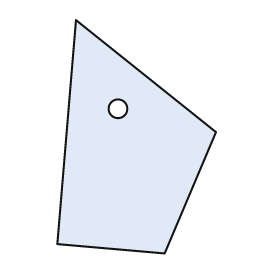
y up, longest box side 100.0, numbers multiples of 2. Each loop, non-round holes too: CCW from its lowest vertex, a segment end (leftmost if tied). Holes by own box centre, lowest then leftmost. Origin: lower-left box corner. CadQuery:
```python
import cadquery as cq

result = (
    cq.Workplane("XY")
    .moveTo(46.0, 0.0)
    .lineTo(68.0, 52.0)
    .lineTo(8.0, 100.0)
    .lineTo(0.0, 4.0)
    .close()
    .moveTo(26.0, 62.0)
    .circle(4.0)
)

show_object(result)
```